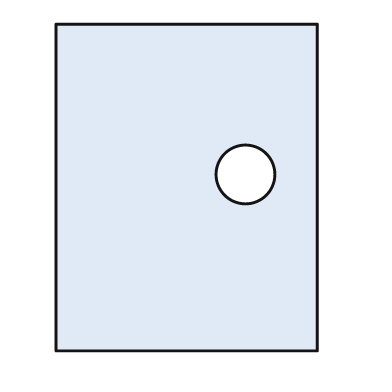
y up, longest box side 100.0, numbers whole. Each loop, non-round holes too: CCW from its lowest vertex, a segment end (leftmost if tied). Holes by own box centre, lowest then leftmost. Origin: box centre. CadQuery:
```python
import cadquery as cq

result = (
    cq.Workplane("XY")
    .moveTo(-40.0, -50.0)
    .lineTo(40.0, -50.0)
    .lineTo(40.0, 50.0)
    .lineTo(-40.0, 50.0)
    .close()
    .moveTo(18.0, 4.0)
    .circle(9.0)
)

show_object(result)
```